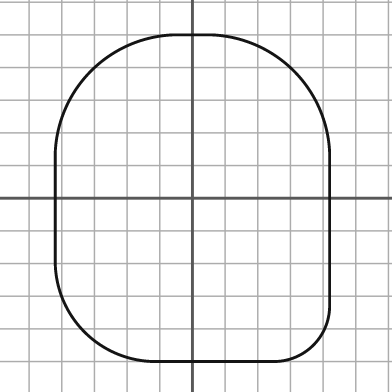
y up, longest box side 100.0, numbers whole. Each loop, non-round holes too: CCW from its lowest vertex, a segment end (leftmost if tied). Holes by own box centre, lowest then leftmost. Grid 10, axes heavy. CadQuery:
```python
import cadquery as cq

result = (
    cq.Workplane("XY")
    .moveTo(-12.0, -50.0)
    .lineTo(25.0, -50.0)
    .threePointArc((37.0, -45.0), (42.0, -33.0))
    .lineTo(42.0, 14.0)
    .threePointArc((31.0, 39.0), (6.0, 50.0))
    .lineTo(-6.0, 50.0)
    .threePointArc((-31.0, 39.0), (-42.0, 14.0))
    .lineTo(-42.0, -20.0)
    .threePointArc((-33.0, -41.0), (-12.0, -50.0))
    .close()
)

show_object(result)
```